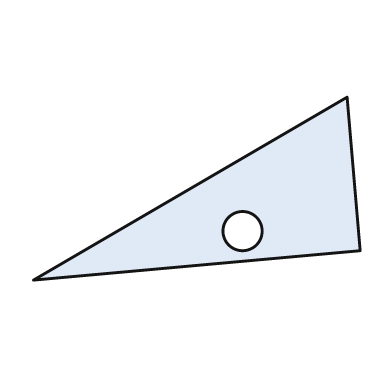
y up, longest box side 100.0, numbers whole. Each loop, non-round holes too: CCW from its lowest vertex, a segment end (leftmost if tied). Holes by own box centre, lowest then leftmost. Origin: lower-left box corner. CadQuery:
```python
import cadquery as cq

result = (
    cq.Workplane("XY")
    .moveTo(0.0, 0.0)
    .lineTo(100.0, 9.0)
    .lineTo(96.0, 56.0)
    .close()
    .moveTo(64.0, 15.0)
    .circle(6.0)
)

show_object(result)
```